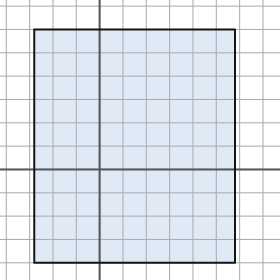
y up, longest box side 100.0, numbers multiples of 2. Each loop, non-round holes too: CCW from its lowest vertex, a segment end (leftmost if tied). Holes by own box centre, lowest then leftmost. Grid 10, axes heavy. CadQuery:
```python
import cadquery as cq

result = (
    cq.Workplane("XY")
    .moveTo(-28.0, -40.0)
    .lineTo(58.0, -40.0)
    .lineTo(58.0, 60.0)
    .lineTo(-28.0, 60.0)
    .close()
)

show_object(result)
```